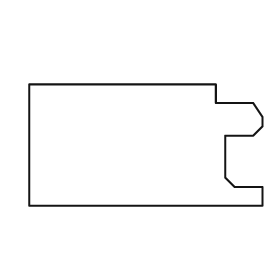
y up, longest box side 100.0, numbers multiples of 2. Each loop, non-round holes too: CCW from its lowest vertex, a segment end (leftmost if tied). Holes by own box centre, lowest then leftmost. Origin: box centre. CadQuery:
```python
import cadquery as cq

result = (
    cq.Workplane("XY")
    .moveTo(-50.0, -26.0)
    .lineTo(50.0, -26.0)
    .lineTo(50.0, -18.0)
    .lineTo(38.0, -18.0)
    .lineTo(34.0, -14.0)
    .lineTo(34.0, 4.0)
    .lineTo(46.0, 4.0)
    .lineTo(50.0, 8.0)
    .lineTo(50.0, 12.0)
    .lineTo(46.0, 18.0)
    .lineTo(30.0, 18.0)
    .lineTo(30.0, 26.0)
    .lineTo(-50.0, 26.0)
    .close()
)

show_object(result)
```